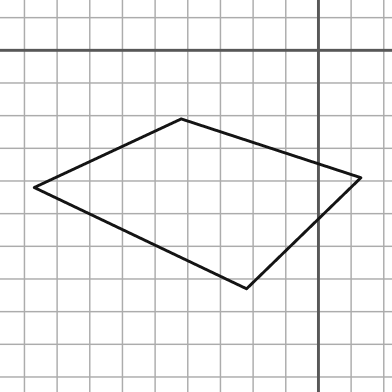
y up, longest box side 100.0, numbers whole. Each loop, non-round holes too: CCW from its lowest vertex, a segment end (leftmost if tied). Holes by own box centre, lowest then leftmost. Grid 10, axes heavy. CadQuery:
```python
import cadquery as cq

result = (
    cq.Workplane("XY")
    .moveTo(-22.0, -73.0)
    .lineTo(13.0, -39.0)
    .lineTo(-42.0, -21.0)
    .lineTo(-87.0, -42.0)
    .close()
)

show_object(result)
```